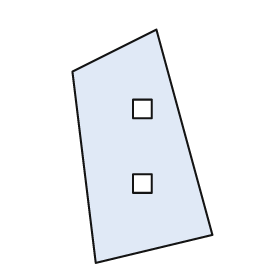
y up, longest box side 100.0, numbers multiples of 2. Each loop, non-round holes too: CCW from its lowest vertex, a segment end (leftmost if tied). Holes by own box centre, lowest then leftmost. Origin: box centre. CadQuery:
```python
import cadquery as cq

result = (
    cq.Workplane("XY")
    .moveTo(-20.0, -50.0)
    .lineTo(30.0, -38.0)
    .lineTo(6.0, 50.0)
    .lineTo(-30.0, 32.0)
    .close()
    .moveTo(-4.0, -20.0)
    .lineTo(4.0, -20.0)
    .lineTo(4.0, -12.0)
    .lineTo(-4.0, -12.0)
    .close()
    .moveTo(-4.0, 12.0)
    .lineTo(4.0, 12.0)
    .lineTo(4.0, 20.0)
    .lineTo(-4.0, 20.0)
    .close()
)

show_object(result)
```